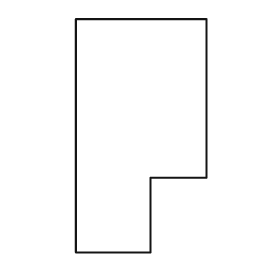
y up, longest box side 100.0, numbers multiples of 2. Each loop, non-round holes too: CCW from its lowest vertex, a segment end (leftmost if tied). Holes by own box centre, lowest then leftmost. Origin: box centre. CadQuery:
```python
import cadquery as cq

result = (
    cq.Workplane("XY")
    .moveTo(-28.0, -50.0)
    .lineTo(4.0, -50.0)
    .lineTo(4.0, -18.0)
    .lineTo(28.0, -18.0)
    .lineTo(28.0, 50.0)
    .lineTo(-28.0, 50.0)
    .close()
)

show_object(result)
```